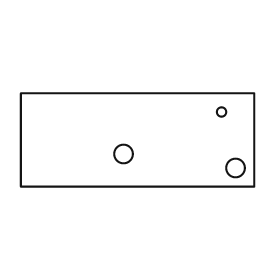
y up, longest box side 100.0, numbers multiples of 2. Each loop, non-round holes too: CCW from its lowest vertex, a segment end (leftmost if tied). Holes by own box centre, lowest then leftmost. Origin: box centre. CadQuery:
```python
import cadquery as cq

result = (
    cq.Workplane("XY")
    .moveTo(-50.0, -20.0)
    .lineTo(50.0, -20.0)
    .lineTo(50.0, 20.0)
    .lineTo(-50.0, 20.0)
    .close()
    .moveTo(42.0, -12.0)
    .circle(4.0)
    .moveTo(-6.0, -6.0)
    .circle(4.0)
    .moveTo(36.0, 12.0)
    .circle(2.0)
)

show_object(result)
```